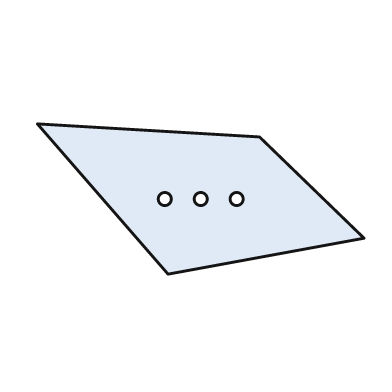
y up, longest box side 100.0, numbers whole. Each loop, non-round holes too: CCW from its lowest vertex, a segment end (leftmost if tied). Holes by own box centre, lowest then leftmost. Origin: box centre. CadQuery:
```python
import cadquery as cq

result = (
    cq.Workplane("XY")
    .moveTo(-10.0, -23.0)
    .lineTo(50.0, -12.0)
    .lineTo(18.0, 19.0)
    .lineTo(-50.0, 23.0)
    .close()
    .moveTo(-11.0, 0.0)
    .circle(2.0)
    .moveTo(0.0, 0.0)
    .circle(2.0)
    .moveTo(11.0, 0.0)
    .circle(2.0)
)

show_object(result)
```